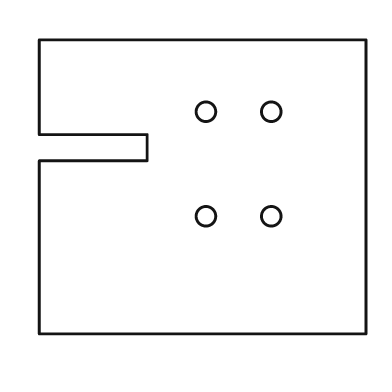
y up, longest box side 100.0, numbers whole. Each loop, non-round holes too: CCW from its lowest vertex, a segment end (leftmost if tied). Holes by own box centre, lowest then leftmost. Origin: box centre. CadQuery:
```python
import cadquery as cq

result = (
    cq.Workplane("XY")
    .moveTo(-50.0, -45.0)
    .lineTo(50.0, -45.0)
    .lineTo(50.0, 45.0)
    .lineTo(-50.0, 45.0)
    .lineTo(-50.0, 16.0)
    .lineTo(-17.0, 16.0)
    .lineTo(-17.0, 8.0)
    .lineTo(-50.0, 8.0)
    .close()
    .moveTo(1.0, -9.0)
    .circle(3.0)
    .moveTo(21.0, -9.0)
    .circle(3.0)
    .moveTo(1.0, 23.0)
    .circle(3.0)
    .moveTo(21.0, 23.0)
    .circle(3.0)
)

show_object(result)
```